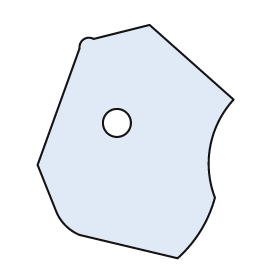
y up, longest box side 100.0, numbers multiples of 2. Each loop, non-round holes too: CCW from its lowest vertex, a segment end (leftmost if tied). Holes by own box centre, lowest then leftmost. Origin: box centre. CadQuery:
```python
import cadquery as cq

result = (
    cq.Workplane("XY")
    .moveTo(18.0, -50.0)
    .threePointArc((28.0, -38.0), (34.0, -24.0))
    .threePointArc((32.0, -2.0), (42.0, 18.0))
    .lineTo(6.0, 50.0)
    .lineTo(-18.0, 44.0)
    .threePointArc((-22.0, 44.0), (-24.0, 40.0))
    .lineTo(-42.0, -10.0)
    .lineTo(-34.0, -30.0)
    .threePointArc((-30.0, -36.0), (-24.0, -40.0))
    .close()
    .moveTo(-8.0, 8.0)
    .circle(6.0)
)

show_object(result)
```